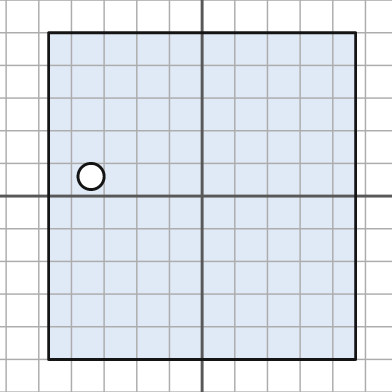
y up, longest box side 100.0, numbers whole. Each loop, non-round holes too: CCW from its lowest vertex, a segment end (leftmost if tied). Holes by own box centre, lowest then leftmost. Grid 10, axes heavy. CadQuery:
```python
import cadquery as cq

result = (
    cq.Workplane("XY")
    .moveTo(-47.0, -50.0)
    .lineTo(47.0, -50.0)
    .lineTo(47.0, 50.0)
    .lineTo(-47.0, 50.0)
    .close()
    .moveTo(-34.0, 6.0)
    .circle(4.0)
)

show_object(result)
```